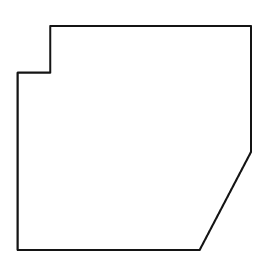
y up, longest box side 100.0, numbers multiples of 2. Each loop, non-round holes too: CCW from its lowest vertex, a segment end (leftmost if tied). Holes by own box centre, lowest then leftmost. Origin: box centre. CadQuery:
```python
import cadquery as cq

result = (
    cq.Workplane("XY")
    .moveTo(-50.0, -48.0)
    .lineTo(28.0, -48.0)
    .lineTo(50.0, -6.0)
    .lineTo(50.0, 48.0)
    .lineTo(-36.0, 48.0)
    .lineTo(-36.0, 28.0)
    .lineTo(-50.0, 28.0)
    .close()
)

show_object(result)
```